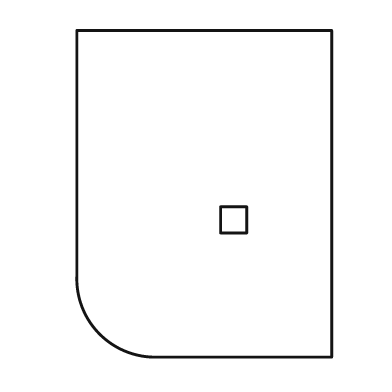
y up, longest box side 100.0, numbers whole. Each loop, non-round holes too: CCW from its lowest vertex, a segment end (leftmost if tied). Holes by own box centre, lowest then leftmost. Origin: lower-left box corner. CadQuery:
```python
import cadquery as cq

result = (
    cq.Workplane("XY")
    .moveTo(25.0, 0.0)
    .lineTo(78.0, 0.0)
    .lineTo(78.0, 100.0)
    .lineTo(0.0, 100.0)
    .lineTo(0.0, 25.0)
    .threePointArc((7.0, 7.0), (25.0, 0.0))
    .close()
    .moveTo(44.0, 38.0)
    .lineTo(52.0, 38.0)
    .lineTo(52.0, 46.0)
    .lineTo(44.0, 46.0)
    .close()
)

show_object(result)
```